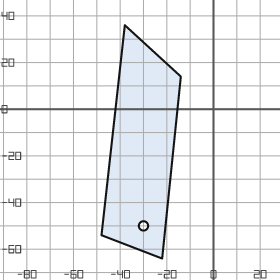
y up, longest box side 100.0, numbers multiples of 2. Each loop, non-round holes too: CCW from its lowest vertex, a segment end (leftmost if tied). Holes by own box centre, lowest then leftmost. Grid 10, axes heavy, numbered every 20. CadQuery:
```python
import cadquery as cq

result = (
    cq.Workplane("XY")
    .moveTo(-22.0, -64.0)
    .lineTo(-14.0, 14.0)
    .lineTo(-38.0, 36.0)
    .lineTo(-48.0, -54.0)
    .close()
    .moveTo(-30.0, -50.0)
    .circle(2.0)
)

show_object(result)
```